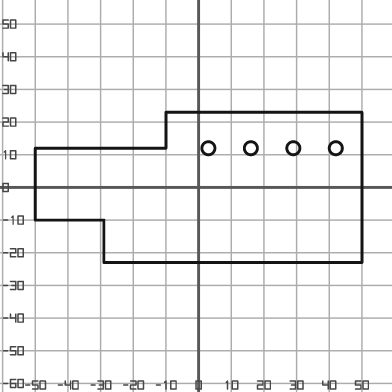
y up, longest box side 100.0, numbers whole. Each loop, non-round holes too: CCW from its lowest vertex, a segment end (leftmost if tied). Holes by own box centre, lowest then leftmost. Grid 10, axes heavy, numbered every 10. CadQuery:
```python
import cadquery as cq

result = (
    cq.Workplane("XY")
    .moveTo(-29.0, -23.0)
    .lineTo(50.0, -23.0)
    .lineTo(50.0, 23.0)
    .lineTo(-10.0, 23.0)
    .lineTo(-10.0, 12.0)
    .lineTo(-50.0, 12.0)
    .lineTo(-50.0, -10.0)
    .lineTo(-29.0, -10.0)
    .close()
    .moveTo(3.0, 12.0)
    .circle(2.0)
    .moveTo(16.0, 12.0)
    .circle(2.0)
    .moveTo(29.0, 12.0)
    .circle(2.0)
    .moveTo(42.0, 12.0)
    .circle(2.0)
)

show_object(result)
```